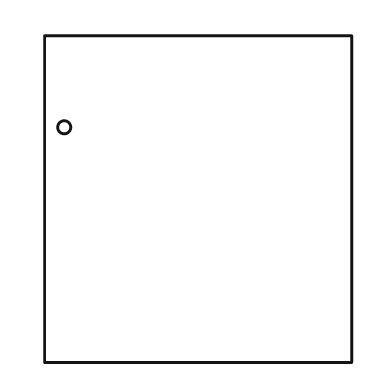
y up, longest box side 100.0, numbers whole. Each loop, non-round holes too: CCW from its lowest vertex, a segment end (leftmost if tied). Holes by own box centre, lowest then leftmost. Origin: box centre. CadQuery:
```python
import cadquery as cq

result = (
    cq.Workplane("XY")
    .moveTo(-47.0, -50.0)
    .lineTo(47.0, -50.0)
    .lineTo(47.0, 50.0)
    .lineTo(-47.0, 50.0)
    .close()
    .moveTo(-41.0, 22.0)
    .circle(2.0)
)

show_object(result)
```